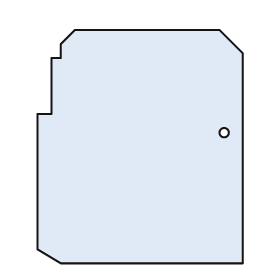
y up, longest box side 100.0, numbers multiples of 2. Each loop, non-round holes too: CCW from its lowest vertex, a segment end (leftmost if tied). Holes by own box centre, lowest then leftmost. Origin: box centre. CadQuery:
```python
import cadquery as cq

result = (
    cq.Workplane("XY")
    .moveTo(-34.0, -50.0)
    .lineTo(44.0, -50.0)
    .lineTo(44.0, 40.0)
    .lineTo(34.0, 50.0)
    .lineTo(-28.0, 50.0)
    .lineTo(-34.0, 44.0)
    .lineTo(-34.0, 38.0)
    .lineTo(-38.0, 38.0)
    .lineTo(-38.0, 14.0)
    .lineTo(-44.0, 14.0)
    .lineTo(-44.0, -44.0)
    .close()
    .moveTo(36.0, 6.0)
    .circle(2.0)
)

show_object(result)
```